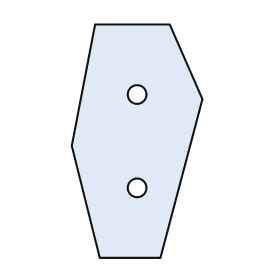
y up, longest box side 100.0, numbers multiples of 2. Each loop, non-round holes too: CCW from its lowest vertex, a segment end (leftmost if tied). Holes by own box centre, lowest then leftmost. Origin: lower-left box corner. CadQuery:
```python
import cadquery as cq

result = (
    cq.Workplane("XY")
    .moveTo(12.0, 0.0)
    .lineTo(38.0, 0.0)
    .lineTo(56.0, 68.0)
    .lineTo(42.0, 100.0)
    .lineTo(10.0, 100.0)
    .lineTo(0.0, 48.0)
    .close()
    .moveTo(28.0, 30.0)
    .circle(4.0)
    .moveTo(28.0, 70.0)
    .circle(4.0)
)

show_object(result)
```